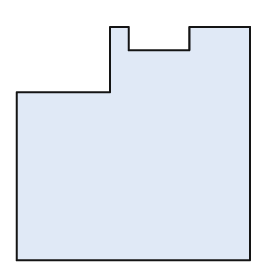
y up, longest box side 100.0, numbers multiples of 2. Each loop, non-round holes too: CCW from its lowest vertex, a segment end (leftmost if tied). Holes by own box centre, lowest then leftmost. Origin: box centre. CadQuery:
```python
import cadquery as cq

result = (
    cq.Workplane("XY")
    .moveTo(-50.0, -50.0)
    .lineTo(50.0, -50.0)
    .lineTo(50.0, 50.0)
    .lineTo(24.0, 50.0)
    .lineTo(24.0, 40.0)
    .lineTo(-2.0, 40.0)
    .lineTo(-2.0, 50.0)
    .lineTo(-10.0, 50.0)
    .lineTo(-10.0, 22.0)
    .lineTo(-50.0, 22.0)
    .close()
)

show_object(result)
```